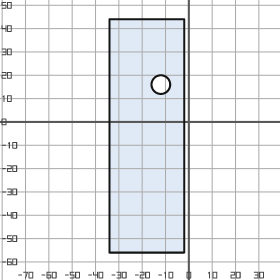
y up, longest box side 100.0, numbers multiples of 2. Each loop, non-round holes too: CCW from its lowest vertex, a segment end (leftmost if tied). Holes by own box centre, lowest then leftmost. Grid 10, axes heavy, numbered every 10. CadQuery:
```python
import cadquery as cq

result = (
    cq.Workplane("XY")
    .moveTo(-34.0, -56.0)
    .lineTo(-2.0, -56.0)
    .lineTo(-2.0, 44.0)
    .lineTo(-34.0, 44.0)
    .close()
    .moveTo(-12.0, 16.0)
    .circle(4.0)
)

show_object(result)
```